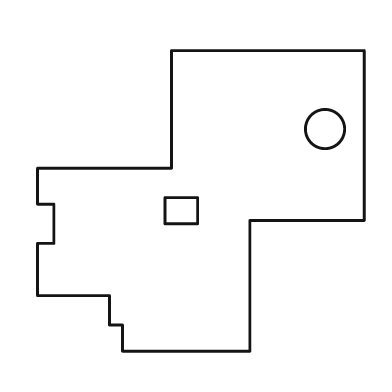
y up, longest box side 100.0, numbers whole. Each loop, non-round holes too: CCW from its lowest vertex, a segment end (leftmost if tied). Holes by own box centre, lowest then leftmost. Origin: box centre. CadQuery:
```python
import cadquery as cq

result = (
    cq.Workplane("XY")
    .moveTo(-24.0, -46.0)
    .lineTo(15.0, -46.0)
    .lineTo(15.0, -6.0)
    .lineTo(50.0, -6.0)
    .lineTo(50.0, 46.0)
    .lineTo(-9.0, 46.0)
    .lineTo(-9.0, 10.0)
    .lineTo(-50.0, 10.0)
    .lineTo(-50.0, -1.0)
    .lineTo(-45.0, -1.0)
    .lineTo(-45.0, -13.0)
    .lineTo(-50.0, -13.0)
    .lineTo(-50.0, -29.0)
    .lineTo(-28.0, -29.0)
    .lineTo(-28.0, -38.0)
    .lineTo(-24.0, -38.0)
    .close()
    .moveTo(-11.0, -7.0)
    .lineTo(-1.0, -7.0)
    .lineTo(-1.0, 1.0)
    .lineTo(-11.0, 1.0)
    .close()
    .moveTo(38.0, 22.0)
    .circle(6.0)
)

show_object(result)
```